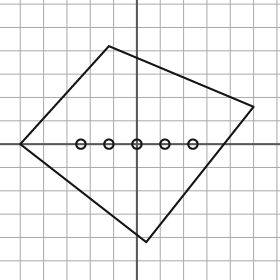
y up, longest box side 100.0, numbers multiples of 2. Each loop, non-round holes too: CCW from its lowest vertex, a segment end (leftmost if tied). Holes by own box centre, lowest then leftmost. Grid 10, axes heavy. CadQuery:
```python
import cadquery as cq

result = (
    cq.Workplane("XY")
    .moveTo(4.0, -42.0)
    .lineTo(50.0, 16.0)
    .lineTo(-12.0, 42.0)
    .lineTo(-50.0, 0.0)
    .close()
    .moveTo(-24.0, 0.0)
    .circle(2.0)
    .moveTo(-12.0, 0.0)
    .circle(2.0)
    .moveTo(0.0, 0.0)
    .circle(2.0)
    .moveTo(12.0, 0.0)
    .circle(2.0)
    .moveTo(24.0, 0.0)
    .circle(2.0)
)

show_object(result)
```